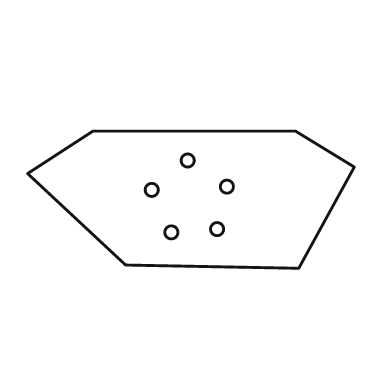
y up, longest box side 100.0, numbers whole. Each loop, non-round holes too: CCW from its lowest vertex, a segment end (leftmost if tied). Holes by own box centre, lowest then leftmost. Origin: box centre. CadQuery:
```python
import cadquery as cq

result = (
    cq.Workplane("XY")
    .moveTo(33.0, -21.0)
    .lineTo(50.0, 10.0)
    .lineTo(32.0, 21.0)
    .lineTo(-30.0, 21.0)
    .lineTo(-50.0, 8.0)
    .lineTo(-20.0, -20.0)
    .close()
    .moveTo(-6.0, -10.0)
    .circle(2.0)
    .moveTo(8.0, -9.0)
    .circle(2.0)
    .moveTo(-12.0, 3.0)
    .circle(2.0)
    .moveTo(11.0, 4.0)
    .circle(2.0)
    .moveTo(-1.0, 12.0)
    .circle(2.0)
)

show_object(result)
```